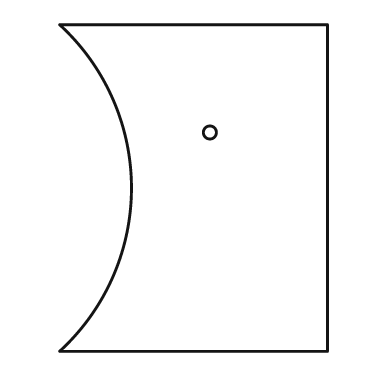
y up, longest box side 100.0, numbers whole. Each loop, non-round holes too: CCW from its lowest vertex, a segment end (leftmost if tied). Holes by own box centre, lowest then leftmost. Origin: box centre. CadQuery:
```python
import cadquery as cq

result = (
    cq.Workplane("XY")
    .moveTo(-41.0, -50.0)
    .lineTo(41.0, -50.0)
    .lineTo(41.0, 50.0)
    .lineTo(-41.0, 50.0)
    .threePointArc((-19.0, 0.0), (-41.0, -50.0))
    .close()
    .moveTo(5.0, 17.0)
    .circle(2.0)
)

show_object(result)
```